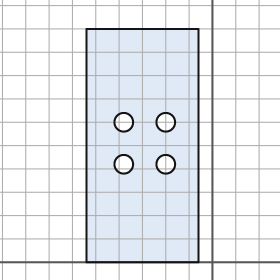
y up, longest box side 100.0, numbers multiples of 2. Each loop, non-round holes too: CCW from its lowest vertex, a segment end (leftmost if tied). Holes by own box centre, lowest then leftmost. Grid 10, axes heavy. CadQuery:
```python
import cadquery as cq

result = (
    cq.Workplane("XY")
    .moveTo(-54.0, 0.0)
    .lineTo(-6.0, 0.0)
    .lineTo(-6.0, 100.0)
    .lineTo(-54.0, 100.0)
    .close()
    .moveTo(-38.0, 42.0)
    .circle(4.0)
    .moveTo(-20.0, 42.0)
    .circle(4.0)
    .moveTo(-38.0, 60.0)
    .circle(4.0)
    .moveTo(-20.0, 60.0)
    .circle(4.0)
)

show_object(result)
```